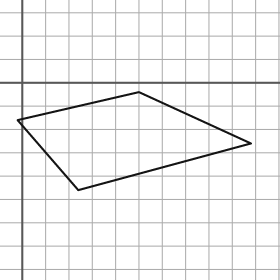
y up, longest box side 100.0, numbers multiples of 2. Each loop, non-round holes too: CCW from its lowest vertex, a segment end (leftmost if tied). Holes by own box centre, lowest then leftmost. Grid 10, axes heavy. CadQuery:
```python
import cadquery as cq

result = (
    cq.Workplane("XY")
    .moveTo(24.0, -46.0)
    .lineTo(98.0, -26.0)
    .lineTo(50.0, -4.0)
    .lineTo(-2.0, -16.0)
    .close()
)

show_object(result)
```